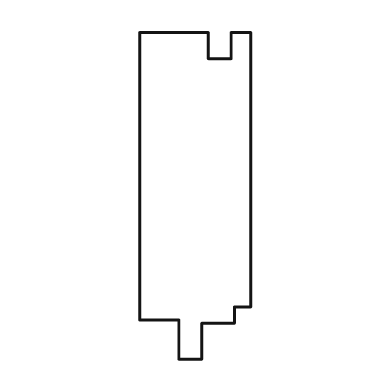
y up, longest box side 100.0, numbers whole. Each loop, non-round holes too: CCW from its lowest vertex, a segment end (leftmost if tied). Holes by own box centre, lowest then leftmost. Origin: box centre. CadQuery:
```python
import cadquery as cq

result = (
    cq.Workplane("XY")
    .moveTo(-5.0, -50.0)
    .lineTo(2.0, -50.0)
    .lineTo(2.0, -39.0)
    .lineTo(12.0, -39.0)
    .lineTo(12.0, -34.0)
    .lineTo(17.0, -34.0)
    .lineTo(17.0, 50.0)
    .lineTo(11.0, 50.0)
    .lineTo(11.0, 42.0)
    .lineTo(4.0, 42.0)
    .lineTo(4.0, 50.0)
    .lineTo(-17.0, 50.0)
    .lineTo(-17.0, -38.0)
    .lineTo(-5.0, -38.0)
    .close()
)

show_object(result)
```